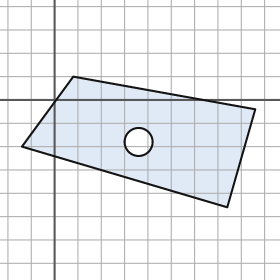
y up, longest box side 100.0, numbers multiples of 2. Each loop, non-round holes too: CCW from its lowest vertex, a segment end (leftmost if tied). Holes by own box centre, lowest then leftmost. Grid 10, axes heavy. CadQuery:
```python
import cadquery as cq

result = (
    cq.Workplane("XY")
    .moveTo(74.0, -46.0)
    .lineTo(86.0, -4.0)
    .lineTo(8.0, 10.0)
    .lineTo(-14.0, -20.0)
    .close()
    .moveTo(36.0, -18.0)
    .circle(6.0)
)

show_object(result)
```